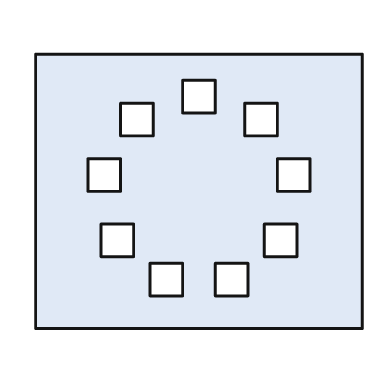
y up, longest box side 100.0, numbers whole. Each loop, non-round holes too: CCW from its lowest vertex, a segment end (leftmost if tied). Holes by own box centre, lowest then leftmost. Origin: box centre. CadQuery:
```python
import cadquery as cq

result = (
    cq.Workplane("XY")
    .moveTo(-50.0, -42.0)
    .lineTo(50.0, -42.0)
    .lineTo(50.0, 42.0)
    .lineTo(-50.0, 42.0)
    .close()
    .moveTo(-15.0, -32.0)
    .lineTo(-5.0, -32.0)
    .lineTo(-5.0, -22.0)
    .lineTo(-15.0, -22.0)
    .close()
    .moveTo(5.0, -32.0)
    .lineTo(15.0, -32.0)
    .lineTo(15.0, -22.0)
    .lineTo(5.0, -22.0)
    .close()
    .moveTo(-30.0, -20.0)
    .lineTo(-20.0, -20.0)
    .lineTo(-20.0, -10.0)
    .lineTo(-30.0, -10.0)
    .close()
    .moveTo(20.0, -20.0)
    .lineTo(30.0, -20.0)
    .lineTo(30.0, -10.0)
    .lineTo(20.0, -10.0)
    .close()
    .moveTo(-34.0, 0.0)
    .lineTo(-24.0, 0.0)
    .lineTo(-24.0, 10.0)
    .lineTo(-34.0, 10.0)
    .close()
    .moveTo(24.0, 0.0)
    .lineTo(34.0, 0.0)
    .lineTo(34.0, 10.0)
    .lineTo(24.0, 10.0)
    .close()
    .moveTo(-24.0, 17.0)
    .lineTo(-14.0, 17.0)
    .lineTo(-14.0, 27.0)
    .lineTo(-24.0, 27.0)
    .close()
    .moveTo(14.0, 17.0)
    .lineTo(24.0, 17.0)
    .lineTo(24.0, 27.0)
    .lineTo(14.0, 27.0)
    .close()
    .moveTo(-5.0, 24.0)
    .lineTo(5.0, 24.0)
    .lineTo(5.0, 34.0)
    .lineTo(-5.0, 34.0)
    .close()
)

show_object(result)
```